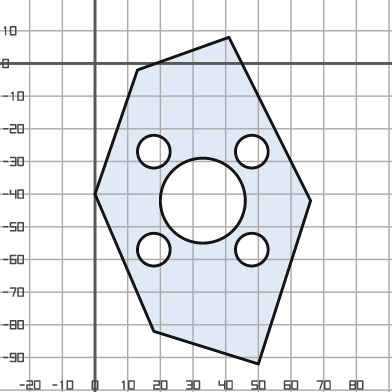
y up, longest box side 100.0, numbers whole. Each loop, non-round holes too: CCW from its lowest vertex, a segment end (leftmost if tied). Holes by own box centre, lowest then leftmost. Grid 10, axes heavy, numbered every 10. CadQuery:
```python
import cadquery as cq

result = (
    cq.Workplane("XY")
    .moveTo(50.0, -92.0)
    .lineTo(66.0, -42.0)
    .lineTo(41.0, 8.0)
    .lineTo(13.0, -2.0)
    .lineTo(0.0, -40.0)
    .lineTo(18.0, -82.0)
    .close()
    .moveTo(18.0, -57.0)
    .circle(5.0)
    .moveTo(48.0, -57.0)
    .circle(5.0)
    .moveTo(33.0, -42.0)
    .circle(13.0)
    .moveTo(18.0, -27.0)
    .circle(5.0)
    .moveTo(48.0, -27.0)
    .circle(5.0)
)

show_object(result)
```